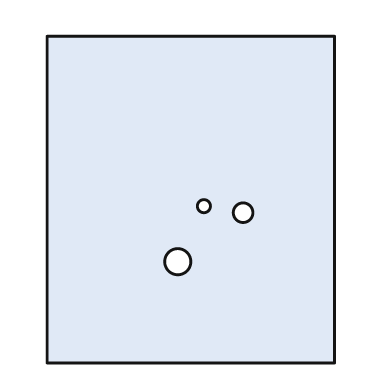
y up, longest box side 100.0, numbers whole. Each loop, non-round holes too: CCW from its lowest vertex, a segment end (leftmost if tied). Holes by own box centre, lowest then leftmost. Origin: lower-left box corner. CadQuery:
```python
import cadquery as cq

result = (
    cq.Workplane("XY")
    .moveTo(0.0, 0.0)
    .lineTo(88.0, 0.0)
    .lineTo(88.0, 100.0)
    .lineTo(0.0, 100.0)
    .close()
    .moveTo(40.0, 31.0)
    .circle(4.0)
    .moveTo(60.0, 46.0)
    .circle(3.0)
    .moveTo(48.0, 48.0)
    .circle(2.0)
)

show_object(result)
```